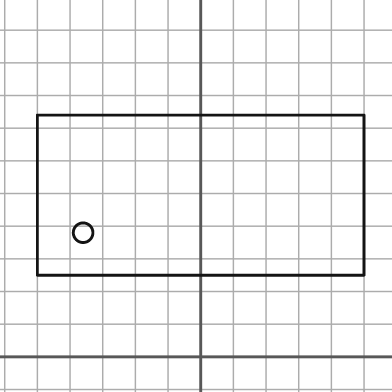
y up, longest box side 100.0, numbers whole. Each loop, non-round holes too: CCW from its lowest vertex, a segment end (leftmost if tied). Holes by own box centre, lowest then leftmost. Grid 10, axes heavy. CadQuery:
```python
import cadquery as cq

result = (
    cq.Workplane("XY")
    .moveTo(-50.0, 25.0)
    .lineTo(50.0, 25.0)
    .lineTo(50.0, 74.0)
    .lineTo(-50.0, 74.0)
    .close()
    .moveTo(-36.0, 38.0)
    .circle(3.0)
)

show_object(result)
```